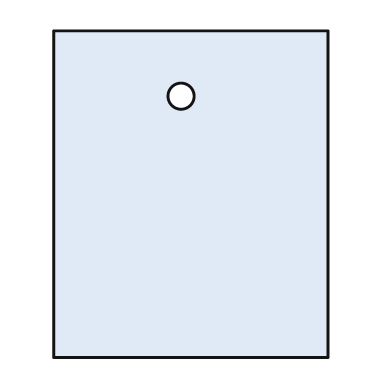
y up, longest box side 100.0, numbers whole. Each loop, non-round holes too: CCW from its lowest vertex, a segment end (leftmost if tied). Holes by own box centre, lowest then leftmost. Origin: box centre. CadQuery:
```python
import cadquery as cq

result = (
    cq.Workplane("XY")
    .moveTo(-42.0, -50.0)
    .lineTo(42.0, -50.0)
    .lineTo(42.0, 50.0)
    .lineTo(-42.0, 50.0)
    .close()
    .moveTo(-3.0, 30.0)
    .circle(4.0)
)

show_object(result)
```